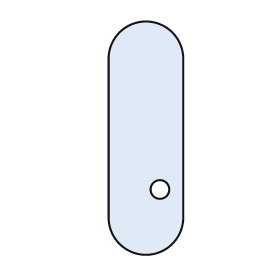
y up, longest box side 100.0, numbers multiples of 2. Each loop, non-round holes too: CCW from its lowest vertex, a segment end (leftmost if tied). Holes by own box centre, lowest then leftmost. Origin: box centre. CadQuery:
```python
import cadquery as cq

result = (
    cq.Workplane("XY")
    .moveTo(-16.0, -34.0)
    .threePointArc((0.0, -50.0), (16.0, -34.0))
    .lineTo(16.0, 34.0)
    .threePointArc((0.0, 50.0), (-16.0, 34.0))
    .close()
    .moveTo(6.0, -22.0)
    .circle(4.0)
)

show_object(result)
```